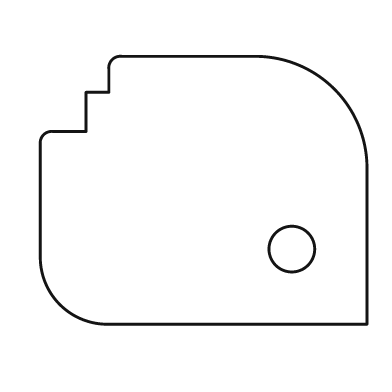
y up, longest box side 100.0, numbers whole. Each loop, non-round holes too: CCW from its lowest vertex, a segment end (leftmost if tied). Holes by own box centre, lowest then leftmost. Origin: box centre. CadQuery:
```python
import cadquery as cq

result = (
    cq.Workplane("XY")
    .moveTo(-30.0, -41.0)
    .lineTo(50.0, -41.0)
    .lineTo(50.0, 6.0)
    .threePointArc((40.0, 31.0), (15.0, 41.0))
    .lineTo(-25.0, 41.0)
    .threePointArc((-28.0, 40.0), (-29.0, 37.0))
    .lineTo(-29.0, 30.0)
    .lineTo(-36.0, 30.0)
    .lineTo(-36.0, 18.0)
    .lineTo(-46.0, 18.0)
    .threePointArc((-49.0, 17.0), (-50.0, 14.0))
    .lineTo(-50.0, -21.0)
    .threePointArc((-44.0, -35.0), (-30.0, -41.0))
    .close()
    .moveTo(27.0, -18.0)
    .circle(7.0)
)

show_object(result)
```